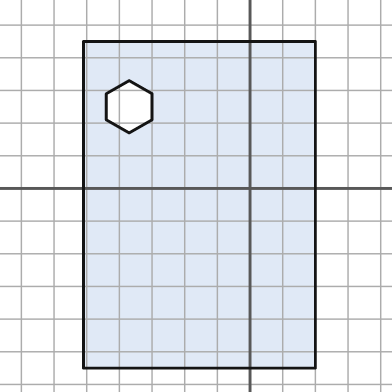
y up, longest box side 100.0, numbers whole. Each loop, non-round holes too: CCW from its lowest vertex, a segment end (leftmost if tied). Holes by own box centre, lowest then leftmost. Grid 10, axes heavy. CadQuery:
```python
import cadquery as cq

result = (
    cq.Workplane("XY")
    .moveTo(-51.0, -55.0)
    .lineTo(20.0, -55.0)
    .lineTo(20.0, 45.0)
    .lineTo(-51.0, 45.0)
    .close()
    .moveTo(-37.0, 17.0)
    .lineTo(-30.0, 21.0)
    .lineTo(-30.0, 29.0)
    .lineTo(-37.0, 33.0)
    .lineTo(-44.0, 29.0)
    .lineTo(-44.0, 21.0)
    .close()
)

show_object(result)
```